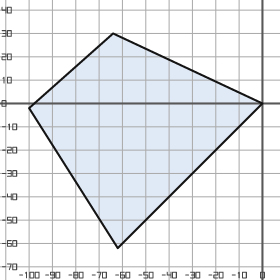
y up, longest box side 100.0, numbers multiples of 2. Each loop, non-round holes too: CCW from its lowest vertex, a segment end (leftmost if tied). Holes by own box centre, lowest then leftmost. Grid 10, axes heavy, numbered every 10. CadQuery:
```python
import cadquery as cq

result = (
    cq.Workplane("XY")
    .moveTo(-62.0, -62.0)
    .lineTo(0.0, 0.0)
    .lineTo(-64.0, 30.0)
    .lineTo(-100.0, -2.0)
    .close()
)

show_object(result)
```